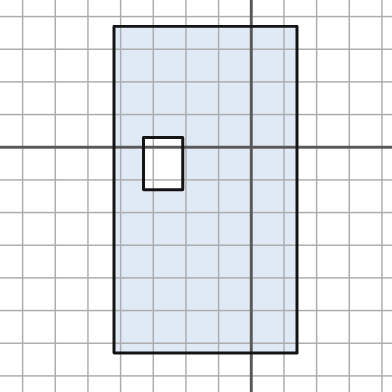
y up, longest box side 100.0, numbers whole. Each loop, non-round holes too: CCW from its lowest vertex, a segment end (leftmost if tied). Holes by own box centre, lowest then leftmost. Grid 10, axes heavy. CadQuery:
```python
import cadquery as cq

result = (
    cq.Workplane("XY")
    .moveTo(-42.0, -63.0)
    .lineTo(14.0, -63.0)
    .lineTo(14.0, 37.0)
    .lineTo(-42.0, 37.0)
    .close()
    .moveTo(-33.0, -13.0)
    .lineTo(-21.0, -13.0)
    .lineTo(-21.0, 3.0)
    .lineTo(-33.0, 3.0)
    .close()
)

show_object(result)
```